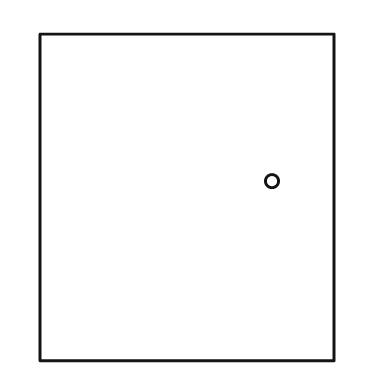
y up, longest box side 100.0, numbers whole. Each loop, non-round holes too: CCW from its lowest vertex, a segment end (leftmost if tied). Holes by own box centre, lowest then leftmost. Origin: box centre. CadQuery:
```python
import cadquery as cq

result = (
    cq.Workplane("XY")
    .moveTo(-45.0, -50.0)
    .lineTo(45.0, -50.0)
    .lineTo(45.0, 50.0)
    .lineTo(-45.0, 50.0)
    .close()
    .moveTo(26.0, 5.0)
    .circle(2.0)
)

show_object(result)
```